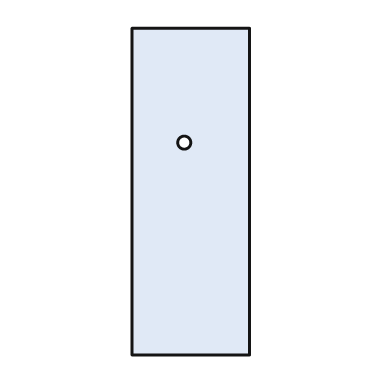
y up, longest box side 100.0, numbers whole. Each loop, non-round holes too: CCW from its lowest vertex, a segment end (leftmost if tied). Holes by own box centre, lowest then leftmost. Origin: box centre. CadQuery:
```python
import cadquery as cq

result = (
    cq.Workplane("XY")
    .moveTo(-18.0, -50.0)
    .lineTo(18.0, -50.0)
    .lineTo(18.0, 50.0)
    .lineTo(-18.0, 50.0)
    .close()
    .moveTo(-2.0, 15.0)
    .circle(2.0)
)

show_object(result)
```